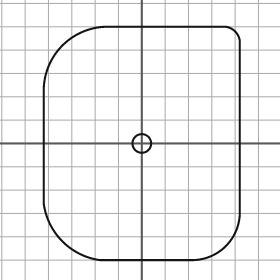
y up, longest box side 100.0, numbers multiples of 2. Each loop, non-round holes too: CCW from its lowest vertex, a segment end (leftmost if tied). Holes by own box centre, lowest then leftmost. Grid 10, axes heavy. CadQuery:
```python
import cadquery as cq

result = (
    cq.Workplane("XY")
    .moveTo(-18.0, -50.0)
    .lineTo(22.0, -50.0)
    .threePointArc((36.0, -44.0), (42.0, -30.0))
    .lineTo(42.0, 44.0)
    .threePointArc((40.0, 48.0), (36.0, 50.0))
    .lineTo(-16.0, 50.0)
    .threePointArc((-34.0, 42.0), (-42.0, 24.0))
    .lineTo(-42.0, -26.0)
    .threePointArc((-34.0, -42.0), (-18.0, -50.0))
    .close()
    .moveTo(0.0, 0.0)
    .circle(4.0)
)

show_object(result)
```